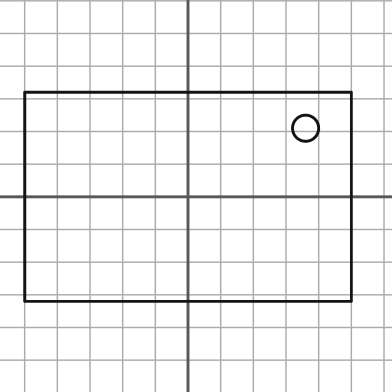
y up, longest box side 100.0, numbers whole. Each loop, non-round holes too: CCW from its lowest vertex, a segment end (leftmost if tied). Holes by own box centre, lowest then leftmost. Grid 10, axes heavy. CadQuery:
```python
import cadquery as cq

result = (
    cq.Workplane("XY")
    .moveTo(-50.0, -32.0)
    .lineTo(50.0, -32.0)
    .lineTo(50.0, 32.0)
    .lineTo(-50.0, 32.0)
    .close()
    .moveTo(36.0, 21.0)
    .circle(4.0)
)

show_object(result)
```